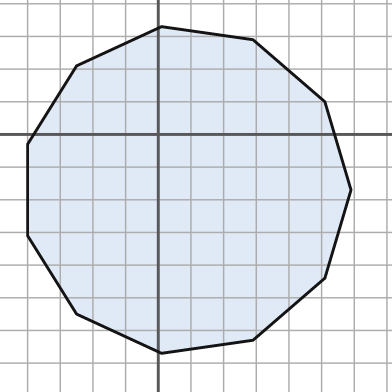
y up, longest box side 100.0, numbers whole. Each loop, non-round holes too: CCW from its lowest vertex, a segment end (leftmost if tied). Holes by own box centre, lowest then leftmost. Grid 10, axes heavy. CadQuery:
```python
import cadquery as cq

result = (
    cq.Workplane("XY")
    .moveTo(1.0, -67.0)
    .lineTo(29.0, -63.0)
    .lineTo(51.0, -44.0)
    .lineTo(59.0, -17.0)
    .lineTo(51.0, 10.0)
    .lineTo(29.0, 29.0)
    .lineTo(1.0, 33.0)
    .lineTo(-25.0, 21.0)
    .lineTo(-40.0, -3.0)
    .lineTo(-40.0, -31.0)
    .lineTo(-25.0, -55.0)
    .close()
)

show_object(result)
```